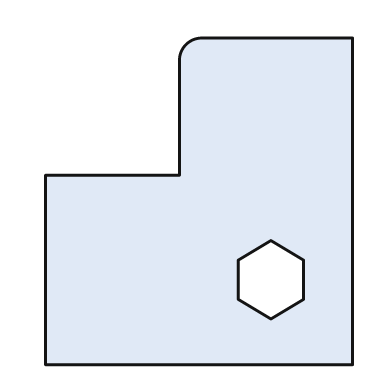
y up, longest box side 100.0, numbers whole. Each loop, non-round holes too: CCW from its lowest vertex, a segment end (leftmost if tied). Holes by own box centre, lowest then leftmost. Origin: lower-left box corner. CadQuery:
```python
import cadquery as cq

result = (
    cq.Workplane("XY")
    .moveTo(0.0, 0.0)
    .lineTo(94.0, 0.0)
    .lineTo(94.0, 100.0)
    .lineTo(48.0, 100.0)
    .threePointArc((43.0, 98.0), (41.0, 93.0))
    .lineTo(41.0, 58.0)
    .lineTo(0.0, 58.0)
    .close()
    .moveTo(69.0, 14.0)
    .lineTo(79.0, 20.0)
    .lineTo(79.0, 32.0)
    .lineTo(69.0, 38.0)
    .lineTo(59.0, 32.0)
    .lineTo(59.0, 20.0)
    .close()
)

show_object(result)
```